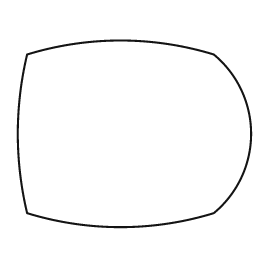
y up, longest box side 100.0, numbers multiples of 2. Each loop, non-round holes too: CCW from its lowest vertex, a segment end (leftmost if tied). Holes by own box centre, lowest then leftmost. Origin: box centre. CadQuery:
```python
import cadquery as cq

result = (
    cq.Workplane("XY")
    .moveTo(-46.0, -34.0)
    .threePointArc((-6.0, -40.0), (34.0, -34.0))
    .threePointArc((50.0, 0.0), (34.0, 34.0))
    .threePointArc((-6.0, 40.0), (-46.0, 34.0))
    .threePointArc((-50.0, 0.0), (-46.0, -34.0))
    .close()
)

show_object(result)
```